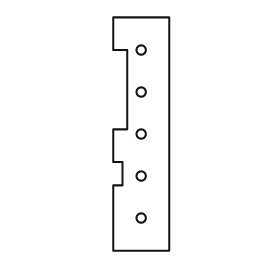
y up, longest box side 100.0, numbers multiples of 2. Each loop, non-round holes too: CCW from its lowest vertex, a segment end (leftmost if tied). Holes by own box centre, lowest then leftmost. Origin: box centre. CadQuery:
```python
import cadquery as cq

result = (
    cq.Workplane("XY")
    .moveTo(-12.0, -50.0)
    .lineTo(12.0, -50.0)
    .lineTo(12.0, 50.0)
    .lineTo(-12.0, 50.0)
    .lineTo(-12.0, 36.0)
    .lineTo(-6.0, 36.0)
    .lineTo(-6.0, 2.0)
    .lineTo(-12.0, 2.0)
    .lineTo(-12.0, -12.0)
    .lineTo(-8.0, -12.0)
    .lineTo(-8.0, -22.0)
    .lineTo(-12.0, -22.0)
    .close()
    .moveTo(0.0, -36.0)
    .circle(2.0)
    .moveTo(0.0, -18.0)
    .circle(2.0)
    .moveTo(0.0, 0.0)
    .circle(2.0)
    .moveTo(0.0, 18.0)
    .circle(2.0)
    .moveTo(0.0, 36.0)
    .circle(2.0)
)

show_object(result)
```